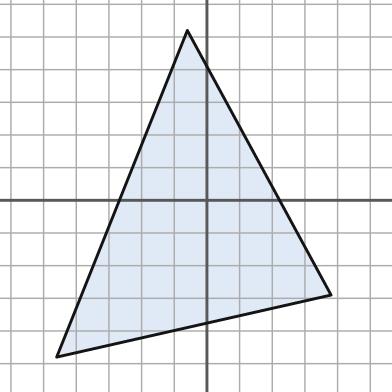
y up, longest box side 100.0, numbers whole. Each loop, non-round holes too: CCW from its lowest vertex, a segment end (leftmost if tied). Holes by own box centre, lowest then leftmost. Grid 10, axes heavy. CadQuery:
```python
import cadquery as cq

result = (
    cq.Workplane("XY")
    .moveTo(-46.0, -48.0)
    .lineTo(38.0, -29.0)
    .lineTo(-6.0, 52.0)
    .close()
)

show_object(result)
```